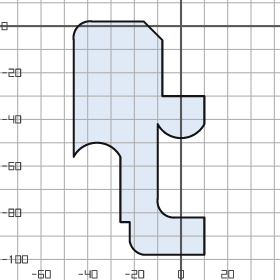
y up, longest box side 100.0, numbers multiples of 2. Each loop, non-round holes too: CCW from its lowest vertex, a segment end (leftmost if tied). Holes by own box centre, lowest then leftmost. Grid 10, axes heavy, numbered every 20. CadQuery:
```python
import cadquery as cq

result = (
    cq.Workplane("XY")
    .moveTo(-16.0, -98.0)
    .lineTo(10.0, -98.0)
    .lineTo(10.0, -82.0)
    .lineTo(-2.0, -82.0)
    .threePointArc((-8.0, -80.0), (-10.0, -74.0))
    .lineTo(-10.0, -42.0)
    .threePointArc((0.0, -48.0), (10.0, -42.0))
    .lineTo(10.0, -30.0)
    .lineTo(-8.0, -30.0)
    .lineTo(-8.0, -6.0)
    .lineTo(-16.0, 2.0)
    .lineTo(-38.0, 2.0)
    .threePointArc((-44.0, 0.0), (-46.0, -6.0))
    .lineTo(-46.0, -56.0)
    .threePointArc((-36.0, -50.0), (-26.0, -56.0))
    .lineTo(-26.0, -84.0)
    .lineTo(-22.0, -84.0)
    .lineTo(-22.0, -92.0)
    .threePointArc((-20.0, -96.0), (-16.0, -98.0))
    .close()
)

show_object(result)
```